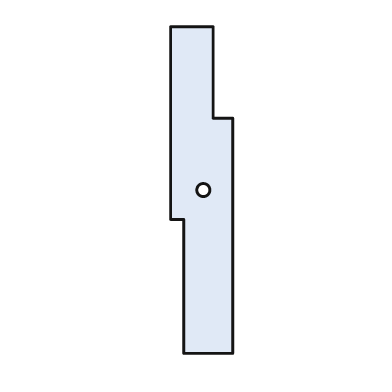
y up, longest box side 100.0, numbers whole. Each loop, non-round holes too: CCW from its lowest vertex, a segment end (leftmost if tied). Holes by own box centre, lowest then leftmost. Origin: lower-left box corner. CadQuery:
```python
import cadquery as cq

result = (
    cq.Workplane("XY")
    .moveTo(4.0, 0.0)
    .lineTo(19.0, 0.0)
    .lineTo(19.0, 72.0)
    .lineTo(13.0, 72.0)
    .lineTo(13.0, 100.0)
    .lineTo(0.0, 100.0)
    .lineTo(0.0, 41.0)
    .lineTo(4.0, 41.0)
    .close()
    .moveTo(10.0, 50.0)
    .circle(2.0)
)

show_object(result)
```